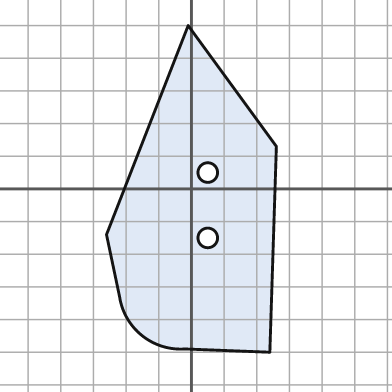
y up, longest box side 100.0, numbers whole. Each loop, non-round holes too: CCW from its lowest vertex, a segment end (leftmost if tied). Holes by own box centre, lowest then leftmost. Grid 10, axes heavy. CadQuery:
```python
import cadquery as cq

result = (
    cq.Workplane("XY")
    .moveTo(24.0, -50.0)
    .lineTo(26.0, 13.0)
    .lineTo(-1.0, 50.0)
    .lineTo(-26.0, -14.0)
    .lineTo(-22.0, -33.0)
    .threePointArc((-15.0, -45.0), (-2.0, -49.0))
    .close()
    .moveTo(5.0, -15.0)
    .circle(3.0)
    .moveTo(5.0, 5.0)
    .circle(3.0)
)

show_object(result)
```